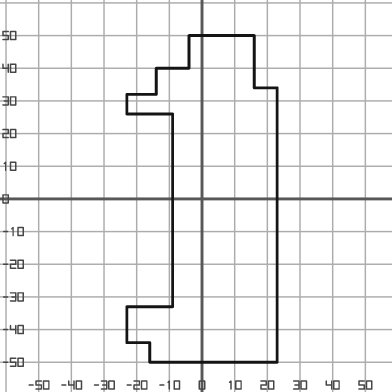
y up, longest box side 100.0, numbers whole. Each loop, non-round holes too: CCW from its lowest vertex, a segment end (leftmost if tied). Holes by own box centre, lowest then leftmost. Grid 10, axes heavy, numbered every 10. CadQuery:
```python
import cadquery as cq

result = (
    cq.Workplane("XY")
    .moveTo(-16.0, -50.0)
    .lineTo(23.0, -50.0)
    .lineTo(23.0, 34.0)
    .lineTo(16.0, 34.0)
    .lineTo(16.0, 50.0)
    .lineTo(-4.0, 50.0)
    .lineTo(-4.0, 40.0)
    .lineTo(-14.0, 40.0)
    .lineTo(-14.0, 32.0)
    .lineTo(-23.0, 32.0)
    .lineTo(-23.0, 26.0)
    .lineTo(-9.0, 26.0)
    .lineTo(-9.0, -33.0)
    .lineTo(-23.0, -33.0)
    .lineTo(-23.0, -44.0)
    .lineTo(-16.0, -44.0)
    .close()
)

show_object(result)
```